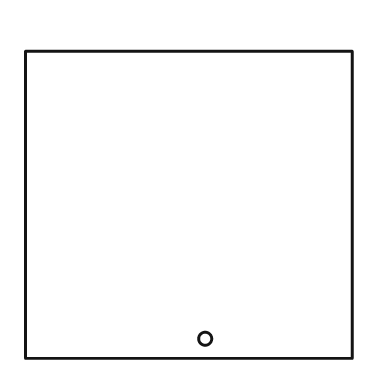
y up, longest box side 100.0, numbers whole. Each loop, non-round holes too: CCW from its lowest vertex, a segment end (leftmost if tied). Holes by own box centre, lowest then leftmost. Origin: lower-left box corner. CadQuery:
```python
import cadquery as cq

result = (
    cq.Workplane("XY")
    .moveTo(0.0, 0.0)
    .lineTo(100.0, 0.0)
    .lineTo(100.0, 94.0)
    .lineTo(0.0, 94.0)
    .close()
    .moveTo(55.0, 6.0)
    .circle(2.0)
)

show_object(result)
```